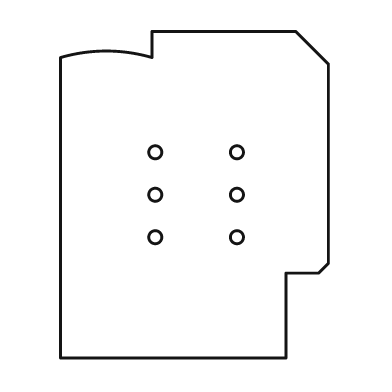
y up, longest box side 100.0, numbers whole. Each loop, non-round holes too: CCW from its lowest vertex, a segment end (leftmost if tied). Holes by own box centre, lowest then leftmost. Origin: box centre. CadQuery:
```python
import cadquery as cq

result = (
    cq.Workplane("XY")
    .moveTo(-41.0, -50.0)
    .lineTo(28.0, -50.0)
    .lineTo(28.0, -24.0)
    .lineTo(38.0, -24.0)
    .lineTo(41.0, -21.0)
    .lineTo(41.0, 40.0)
    .lineTo(31.0, 50.0)
    .lineTo(-13.0, 50.0)
    .lineTo(-13.0, 42.0)
    .threePointArc((-27.0, 44.0), (-41.0, 42.0))
    .close()
    .moveTo(-12.0, -13.0)
    .circle(2.0)
    .moveTo(13.0, -13.0)
    .circle(2.0)
    .moveTo(-12.0, 0.0)
    .circle(2.0)
    .moveTo(13.0, 0.0)
    .circle(2.0)
    .moveTo(-12.0, 13.0)
    .circle(2.0)
    .moveTo(13.0, 13.0)
    .circle(2.0)
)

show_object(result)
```